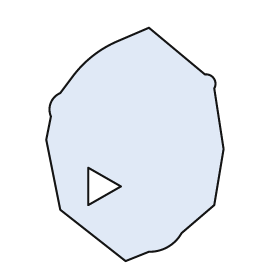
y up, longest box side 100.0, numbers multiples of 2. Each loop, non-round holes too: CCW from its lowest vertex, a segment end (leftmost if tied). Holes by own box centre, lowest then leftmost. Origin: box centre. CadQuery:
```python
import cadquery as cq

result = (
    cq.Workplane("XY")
    .moveTo(-4.0, -50.0)
    .lineTo(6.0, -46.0)
    .threePointArc((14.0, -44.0), (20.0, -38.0))
    .lineTo(34.0, -26.0)
    .lineTo(38.0, -2.0)
    .lineTo(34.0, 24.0)
    .threePointArc((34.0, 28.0), (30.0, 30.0))
    .lineTo(6.0, 50.0)
    .lineTo(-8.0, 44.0)
    .threePointArc((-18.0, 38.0), (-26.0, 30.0))
    .lineTo(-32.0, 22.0)
    .threePointArc((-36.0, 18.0), (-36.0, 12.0))
    .lineTo(-38.0, 2.0)
    .lineTo(-32.0, -28.0)
    .close()
    .moveTo(-20.0, -26.0)
    .lineTo(-6.0, -18.0)
    .lineTo(-20.0, -10.0)
    .close()
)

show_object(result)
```